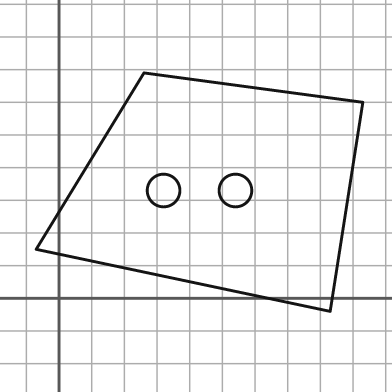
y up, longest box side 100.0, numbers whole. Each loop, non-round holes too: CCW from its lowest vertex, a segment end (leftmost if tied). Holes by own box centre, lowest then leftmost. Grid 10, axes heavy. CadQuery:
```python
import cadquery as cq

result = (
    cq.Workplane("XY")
    .moveTo(83.0, -4.0)
    .lineTo(93.0, 60.0)
    .lineTo(26.0, 69.0)
    .lineTo(-7.0, 15.0)
    .close()
    .moveTo(32.0, 33.0)
    .circle(5.0)
    .moveTo(54.0, 33.0)
    .circle(5.0)
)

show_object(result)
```